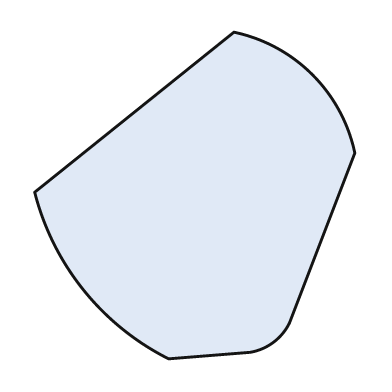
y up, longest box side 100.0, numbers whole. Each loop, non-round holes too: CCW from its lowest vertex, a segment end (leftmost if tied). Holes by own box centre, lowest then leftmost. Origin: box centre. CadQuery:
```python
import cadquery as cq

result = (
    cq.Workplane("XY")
    .moveTo(-8.0, -50.0)
    .lineTo(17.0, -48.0)
    .threePointArc((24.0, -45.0), (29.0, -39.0))
    .lineTo(49.0, 13.0)
    .threePointArc((36.0, 37.0), (12.0, 50.0))
    .lineTo(-49.0, 1.0)
    .threePointArc((-34.0, -29.0), (-8.0, -50.0))
    .close()
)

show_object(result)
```